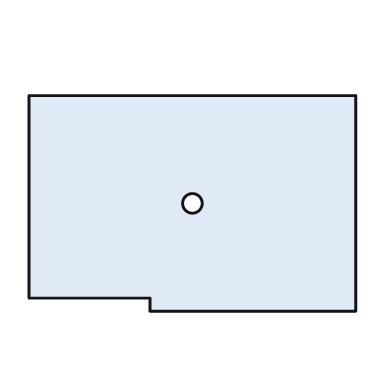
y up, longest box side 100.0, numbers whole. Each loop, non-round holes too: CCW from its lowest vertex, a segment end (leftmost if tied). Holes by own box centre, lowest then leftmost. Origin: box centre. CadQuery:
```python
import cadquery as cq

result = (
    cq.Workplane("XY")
    .moveTo(-13.0, -33.0)
    .lineTo(50.0, -33.0)
    .lineTo(50.0, 33.0)
    .lineTo(-50.0, 33.0)
    .lineTo(-50.0, -29.0)
    .lineTo(-13.0, -29.0)
    .close()
    .moveTo(0.0, 0.0)
    .circle(3.0)
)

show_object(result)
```